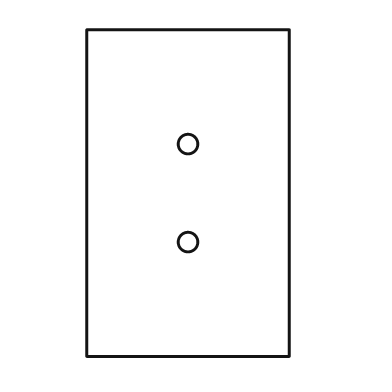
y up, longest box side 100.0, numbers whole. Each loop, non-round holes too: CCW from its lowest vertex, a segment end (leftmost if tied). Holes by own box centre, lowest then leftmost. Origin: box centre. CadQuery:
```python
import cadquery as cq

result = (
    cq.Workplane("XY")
    .moveTo(-31.0, -50.0)
    .lineTo(31.0, -50.0)
    .lineTo(31.0, 50.0)
    .lineTo(-31.0, 50.0)
    .close()
    .moveTo(0.0, -15.0)
    .circle(3.0)
    .moveTo(0.0, 15.0)
    .circle(3.0)
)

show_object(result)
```